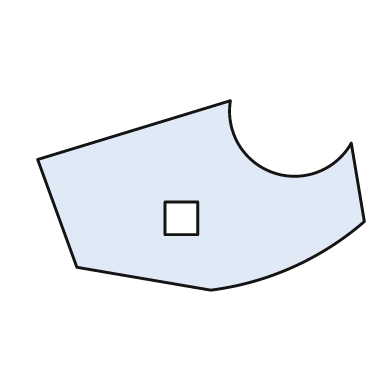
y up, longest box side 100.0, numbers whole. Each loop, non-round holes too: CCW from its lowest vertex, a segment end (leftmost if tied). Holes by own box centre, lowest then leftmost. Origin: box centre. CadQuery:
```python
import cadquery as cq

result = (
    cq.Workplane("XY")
    .moveTo(3.0, -29.0)
    .threePointArc((28.0, -22.0), (50.0, -8.0))
    .lineTo(46.0, 16.0)
    .threePointArc((22.0, 7.0), (9.0, 29.0))
    .lineTo(-50.0, 11.0)
    .lineTo(-38.0, -22.0)
    .close()
    .moveTo(-11.0, -12.0)
    .lineTo(-1.0, -12.0)
    .lineTo(-1.0, -2.0)
    .lineTo(-11.0, -2.0)
    .close()
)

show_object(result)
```